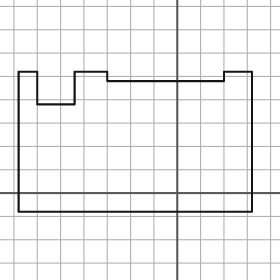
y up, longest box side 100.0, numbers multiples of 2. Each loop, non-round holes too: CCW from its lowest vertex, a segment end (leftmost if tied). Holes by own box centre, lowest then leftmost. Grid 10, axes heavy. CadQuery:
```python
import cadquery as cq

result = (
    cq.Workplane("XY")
    .moveTo(-68.0, -8.0)
    .lineTo(32.0, -8.0)
    .lineTo(32.0, 52.0)
    .lineTo(20.0, 52.0)
    .lineTo(20.0, 48.0)
    .lineTo(-30.0, 48.0)
    .lineTo(-30.0, 52.0)
    .lineTo(-44.0, 52.0)
    .lineTo(-44.0, 38.0)
    .lineTo(-60.0, 38.0)
    .lineTo(-60.0, 52.0)
    .lineTo(-68.0, 52.0)
    .close()
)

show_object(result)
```